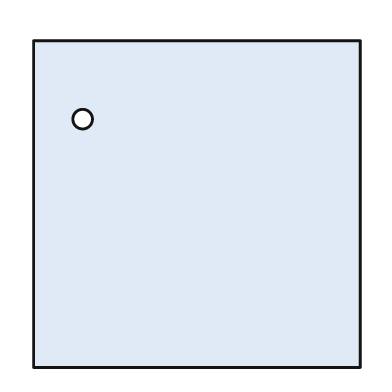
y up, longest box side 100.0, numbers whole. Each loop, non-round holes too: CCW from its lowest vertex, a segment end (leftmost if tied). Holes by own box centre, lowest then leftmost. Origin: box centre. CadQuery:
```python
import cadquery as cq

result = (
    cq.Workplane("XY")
    .moveTo(-50.0, -50.0)
    .lineTo(50.0, -50.0)
    .lineTo(50.0, 50.0)
    .lineTo(-50.0, 50.0)
    .close()
    .moveTo(-35.0, 26.0)
    .circle(3.0)
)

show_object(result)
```